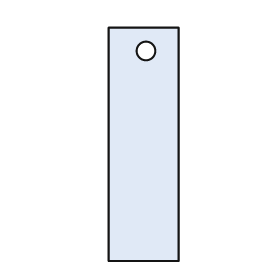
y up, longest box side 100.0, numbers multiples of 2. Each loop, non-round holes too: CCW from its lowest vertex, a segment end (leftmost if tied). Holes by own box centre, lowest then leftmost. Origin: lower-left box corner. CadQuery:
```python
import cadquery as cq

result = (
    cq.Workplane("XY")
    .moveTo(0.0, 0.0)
    .lineTo(30.0, 0.0)
    .lineTo(30.0, 100.0)
    .lineTo(0.0, 100.0)
    .close()
    .moveTo(16.0, 90.0)
    .circle(4.0)
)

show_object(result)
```